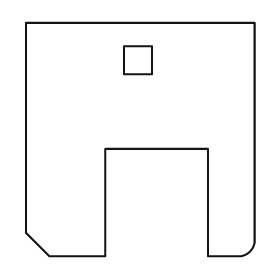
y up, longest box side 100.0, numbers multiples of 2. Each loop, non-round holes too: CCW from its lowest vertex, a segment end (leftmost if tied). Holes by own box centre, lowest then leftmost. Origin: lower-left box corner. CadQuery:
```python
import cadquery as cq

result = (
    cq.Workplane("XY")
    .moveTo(10.0, 0.0)
    .lineTo(34.0, 0.0)
    .lineTo(34.0, 46.0)
    .lineTo(78.0, 46.0)
    .lineTo(78.0, 0.0)
    .lineTo(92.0, 0.0)
    .threePointArc((96.0, 2.0), (98.0, 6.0))
    .lineTo(98.0, 100.0)
    .lineTo(0.0, 100.0)
    .lineTo(0.0, 10.0)
    .close()
    .moveTo(42.0, 78.0)
    .lineTo(54.0, 78.0)
    .lineTo(54.0, 90.0)
    .lineTo(42.0, 90.0)
    .close()
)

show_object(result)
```